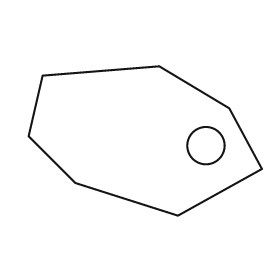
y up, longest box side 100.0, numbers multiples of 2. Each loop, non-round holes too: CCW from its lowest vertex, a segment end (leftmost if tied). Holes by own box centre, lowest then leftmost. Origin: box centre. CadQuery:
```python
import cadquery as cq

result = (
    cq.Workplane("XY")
    .moveTo(14.0, -32.0)
    .lineTo(50.0, -12.0)
    .lineTo(36.0, 14.0)
    .lineTo(6.0, 32.0)
    .lineTo(-44.0, 28.0)
    .lineTo(-50.0, 2.0)
    .lineTo(-30.0, -18.0)
    .close()
    .moveTo(26.0, -2.0)
    .circle(8.0)
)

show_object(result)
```